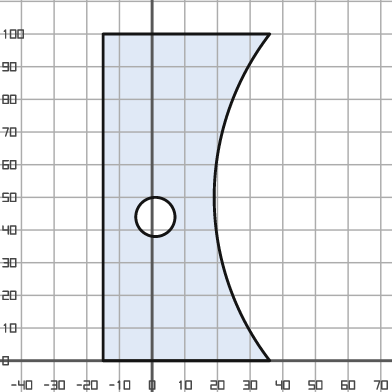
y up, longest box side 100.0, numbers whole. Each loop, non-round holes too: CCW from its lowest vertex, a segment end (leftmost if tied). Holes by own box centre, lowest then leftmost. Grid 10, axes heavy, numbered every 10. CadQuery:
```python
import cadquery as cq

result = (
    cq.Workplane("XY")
    .moveTo(-15.0, 0.0)
    .lineTo(36.0, 0.0)
    .threePointArc((19.0, 50.0), (36.0, 100.0))
    .lineTo(-15.0, 100.0)
    .close()
    .moveTo(1.0, 44.0)
    .circle(6.0)
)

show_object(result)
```